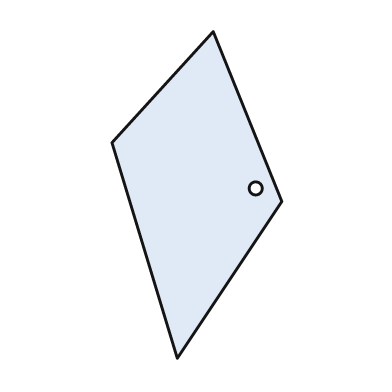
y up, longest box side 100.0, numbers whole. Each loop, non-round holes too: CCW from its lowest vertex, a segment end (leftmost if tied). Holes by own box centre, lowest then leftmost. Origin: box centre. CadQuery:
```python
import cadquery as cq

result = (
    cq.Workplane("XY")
    .moveTo(-6.0, -50.0)
    .lineTo(26.0, -2.0)
    .lineTo(5.0, 50.0)
    .lineTo(-26.0, 16.0)
    .close()
    .moveTo(18.0, 2.0)
    .circle(2.0)
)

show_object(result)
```